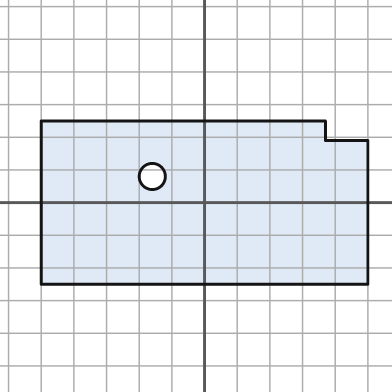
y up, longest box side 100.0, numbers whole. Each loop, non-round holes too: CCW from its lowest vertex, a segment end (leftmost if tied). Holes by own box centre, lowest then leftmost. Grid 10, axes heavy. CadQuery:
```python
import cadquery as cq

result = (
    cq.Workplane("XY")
    .moveTo(-50.0, -25.0)
    .lineTo(50.0, -25.0)
    .lineTo(50.0, 19.0)
    .lineTo(37.0, 19.0)
    .lineTo(37.0, 25.0)
    .lineTo(-50.0, 25.0)
    .close()
    .moveTo(-16.0, 8.0)
    .circle(4.0)
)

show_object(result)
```